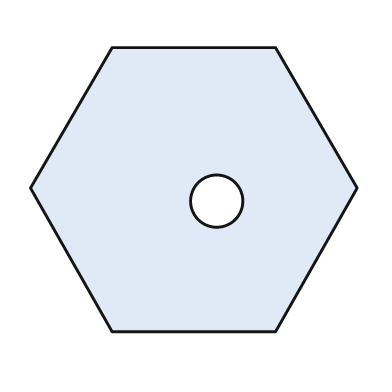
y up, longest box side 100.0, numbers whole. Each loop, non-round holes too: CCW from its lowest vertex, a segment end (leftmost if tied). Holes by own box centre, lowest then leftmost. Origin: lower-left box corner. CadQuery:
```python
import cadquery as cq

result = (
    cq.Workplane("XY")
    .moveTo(25.0, 0.0)
    .lineTo(75.0, 0.0)
    .lineTo(100.0, 44.0)
    .lineTo(75.0, 87.0)
    .lineTo(25.0, 87.0)
    .lineTo(0.0, 44.0)
    .close()
    .moveTo(57.0, 40.0)
    .circle(8.0)
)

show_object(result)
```